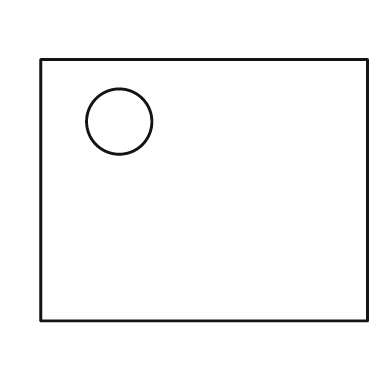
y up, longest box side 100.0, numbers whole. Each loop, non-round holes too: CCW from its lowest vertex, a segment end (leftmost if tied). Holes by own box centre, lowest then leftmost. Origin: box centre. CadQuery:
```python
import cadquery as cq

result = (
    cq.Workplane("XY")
    .moveTo(-50.0, -40.0)
    .lineTo(50.0, -40.0)
    .lineTo(50.0, 40.0)
    .lineTo(-50.0, 40.0)
    .close()
    .moveTo(-26.0, 21.0)
    .circle(10.0)
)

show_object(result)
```